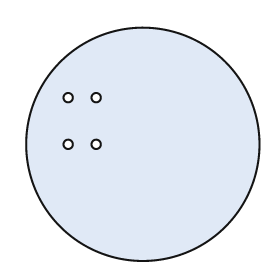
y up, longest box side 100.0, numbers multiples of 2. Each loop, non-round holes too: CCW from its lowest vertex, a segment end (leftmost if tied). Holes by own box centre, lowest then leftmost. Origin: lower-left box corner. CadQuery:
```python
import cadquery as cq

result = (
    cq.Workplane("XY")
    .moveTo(50.0, 50.0)
    .circle(50.0)
    .moveTo(18.0, 50.0)
    .circle(2.0)
    .moveTo(30.0, 50.0)
    .circle(2.0)
    .moveTo(18.0, 70.0)
    .circle(2.0)
    .moveTo(30.0, 70.0)
    .circle(2.0)
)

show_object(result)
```